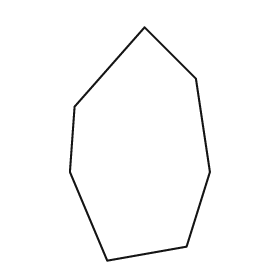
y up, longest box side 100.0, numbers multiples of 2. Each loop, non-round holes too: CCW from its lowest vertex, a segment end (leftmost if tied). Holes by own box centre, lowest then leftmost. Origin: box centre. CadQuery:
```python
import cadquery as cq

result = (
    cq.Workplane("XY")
    .moveTo(-14.0, -50.0)
    .lineTo(20.0, -44.0)
    .lineTo(30.0, -12.0)
    .lineTo(24.0, 28.0)
    .lineTo(2.0, 50.0)
    .lineTo(-28.0, 16.0)
    .lineTo(-30.0, -12.0)
    .close()
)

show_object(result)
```